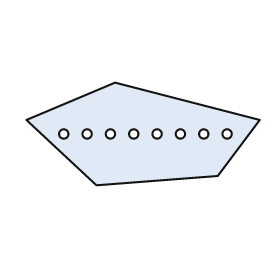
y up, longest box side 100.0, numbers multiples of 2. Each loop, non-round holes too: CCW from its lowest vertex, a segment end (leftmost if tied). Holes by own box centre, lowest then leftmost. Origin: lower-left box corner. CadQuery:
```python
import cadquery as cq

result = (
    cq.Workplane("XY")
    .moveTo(30.0, 0.0)
    .lineTo(82.0, 4.0)
    .lineTo(100.0, 28.0)
    .lineTo(38.0, 44.0)
    .lineTo(0.0, 28.0)
    .close()
    .moveTo(16.0, 22.0)
    .circle(2.0)
    .moveTo(26.0, 22.0)
    .circle(2.0)
    .moveTo(36.0, 22.0)
    .circle(2.0)
    .moveTo(46.0, 22.0)
    .circle(2.0)
    .moveTo(56.0, 22.0)
    .circle(2.0)
    .moveTo(66.0, 22.0)
    .circle(2.0)
    .moveTo(76.0, 22.0)
    .circle(2.0)
    .moveTo(86.0, 22.0)
    .circle(2.0)
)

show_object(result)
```